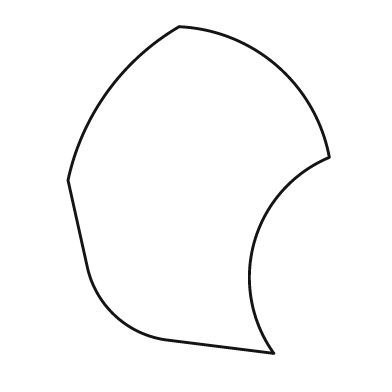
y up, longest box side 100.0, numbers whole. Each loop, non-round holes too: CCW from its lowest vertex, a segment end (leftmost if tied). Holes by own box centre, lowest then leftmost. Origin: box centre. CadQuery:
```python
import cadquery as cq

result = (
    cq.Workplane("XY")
    .moveTo(23.0, -50.0)
    .threePointArc((17.0, -16.0), (40.0, 10.0))
    .threePointArc((24.0, 38.0), (-6.0, 50.0))
    .threePointArc((-28.0, 30.0), (-40.0, 3.0))
    .lineTo(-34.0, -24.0)
    .threePointArc((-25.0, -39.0), (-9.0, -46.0))
    .close()
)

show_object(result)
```